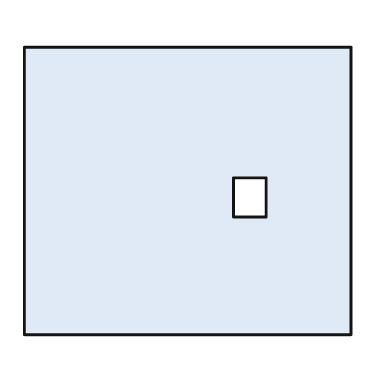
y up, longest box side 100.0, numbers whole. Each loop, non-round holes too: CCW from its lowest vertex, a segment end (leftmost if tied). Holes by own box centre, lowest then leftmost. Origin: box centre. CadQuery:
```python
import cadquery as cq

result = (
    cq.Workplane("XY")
    .moveTo(-50.0, -44.0)
    .lineTo(50.0, -44.0)
    .lineTo(50.0, 44.0)
    .lineTo(-50.0, 44.0)
    .close()
    .moveTo(14.0, -8.0)
    .lineTo(24.0, -8.0)
    .lineTo(24.0, 4.0)
    .lineTo(14.0, 4.0)
    .close()
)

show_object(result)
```